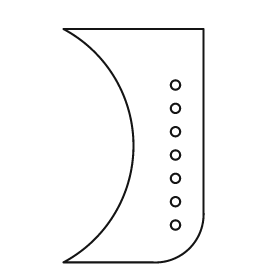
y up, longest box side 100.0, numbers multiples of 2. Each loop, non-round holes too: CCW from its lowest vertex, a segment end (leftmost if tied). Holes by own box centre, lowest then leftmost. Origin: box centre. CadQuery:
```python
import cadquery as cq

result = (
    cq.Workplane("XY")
    .moveTo(-30.0, -50.0)
    .lineTo(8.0, -50.0)
    .threePointArc((24.0, -44.0), (30.0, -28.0))
    .lineTo(30.0, 50.0)
    .lineTo(-30.0, 50.0)
    .threePointArc((0.0, 0.0), (-30.0, -50.0))
    .close()
    .moveTo(18.0, -34.0)
    .circle(2.0)
    .moveTo(18.0, -24.0)
    .circle(2.0)
    .moveTo(18.0, -14.0)
    .circle(2.0)
    .moveTo(18.0, -4.0)
    .circle(2.0)
    .moveTo(18.0, 6.0)
    .circle(2.0)
    .moveTo(18.0, 16.0)
    .circle(2.0)
    .moveTo(18.0, 26.0)
    .circle(2.0)
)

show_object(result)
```